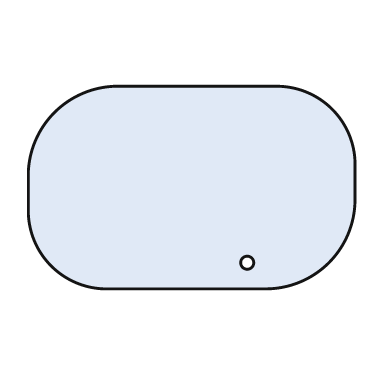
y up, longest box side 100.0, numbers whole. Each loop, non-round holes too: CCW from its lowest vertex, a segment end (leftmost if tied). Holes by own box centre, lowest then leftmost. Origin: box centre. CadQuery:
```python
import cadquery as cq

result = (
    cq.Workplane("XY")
    .moveTo(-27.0, -31.0)
    .lineTo(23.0, -31.0)
    .threePointArc((42.0, -23.0), (50.0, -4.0))
    .lineTo(50.0, 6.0)
    .threePointArc((43.0, 24.0), (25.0, 31.0))
    .lineTo(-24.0, 31.0)
    .threePointArc((-42.0, 23.0), (-50.0, 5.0))
    .lineTo(-50.0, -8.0)
    .threePointArc((-43.0, -24.0), (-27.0, -31.0))
    .close()
    .moveTo(17.0, -23.0)
    .circle(2.0)
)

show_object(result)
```